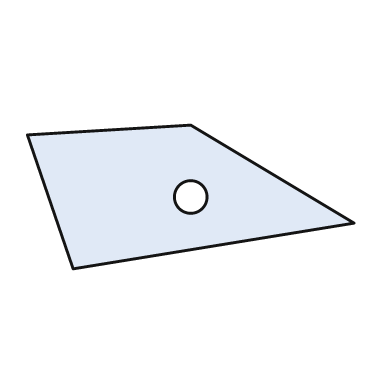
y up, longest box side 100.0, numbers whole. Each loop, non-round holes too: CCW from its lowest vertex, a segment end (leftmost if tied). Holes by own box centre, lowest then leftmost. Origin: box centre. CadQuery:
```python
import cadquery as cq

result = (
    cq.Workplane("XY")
    .moveTo(-36.0, -22.0)
    .lineTo(50.0, -8.0)
    .lineTo(0.0, 22.0)
    .lineTo(-50.0, 19.0)
    .close()
    .moveTo(0.0, 0.0)
    .circle(5.0)
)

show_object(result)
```